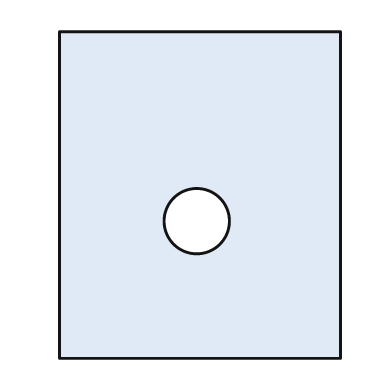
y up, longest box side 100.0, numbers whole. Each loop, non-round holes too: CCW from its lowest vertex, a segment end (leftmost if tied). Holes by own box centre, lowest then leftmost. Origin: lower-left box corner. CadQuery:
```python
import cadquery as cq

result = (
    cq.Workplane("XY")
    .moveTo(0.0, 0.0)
    .lineTo(86.0, 0.0)
    .lineTo(86.0, 100.0)
    .lineTo(0.0, 100.0)
    .close()
    .moveTo(42.0, 42.0)
    .circle(10.0)
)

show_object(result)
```